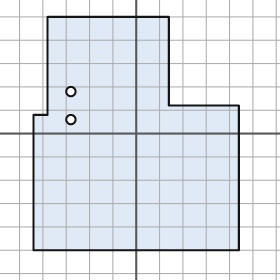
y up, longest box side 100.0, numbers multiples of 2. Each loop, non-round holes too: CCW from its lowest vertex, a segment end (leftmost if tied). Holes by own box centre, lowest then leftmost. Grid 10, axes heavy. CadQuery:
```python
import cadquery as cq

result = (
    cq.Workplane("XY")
    .moveTo(-44.0, -50.0)
    .lineTo(44.0, -50.0)
    .lineTo(44.0, 12.0)
    .lineTo(14.0, 12.0)
    .lineTo(14.0, 50.0)
    .lineTo(-38.0, 50.0)
    .lineTo(-38.0, 8.0)
    .lineTo(-44.0, 8.0)
    .close()
    .moveTo(-28.0, 6.0)
    .circle(2.0)
    .moveTo(-28.0, 18.0)
    .circle(2.0)
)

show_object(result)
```